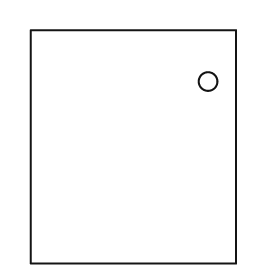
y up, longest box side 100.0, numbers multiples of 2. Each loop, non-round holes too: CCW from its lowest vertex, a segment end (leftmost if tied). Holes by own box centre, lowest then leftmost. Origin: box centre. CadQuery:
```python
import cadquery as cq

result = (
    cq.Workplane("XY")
    .moveTo(-44.0, -50.0)
    .lineTo(44.0, -50.0)
    .lineTo(44.0, 50.0)
    .lineTo(-44.0, 50.0)
    .close()
    .moveTo(32.0, 28.0)
    .circle(4.0)
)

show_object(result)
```